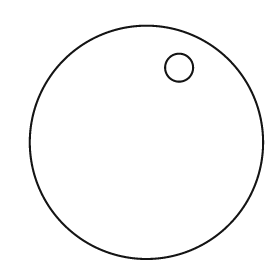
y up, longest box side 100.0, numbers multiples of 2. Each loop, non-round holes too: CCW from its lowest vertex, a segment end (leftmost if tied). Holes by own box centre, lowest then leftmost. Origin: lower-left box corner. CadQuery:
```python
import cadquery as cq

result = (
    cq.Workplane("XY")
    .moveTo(50.0, 50.0)
    .circle(50.0)
    .moveTo(64.0, 82.0)
    .circle(6.0)
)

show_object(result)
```